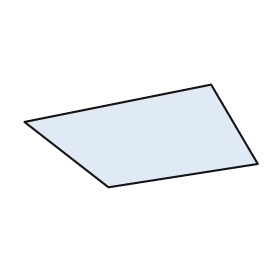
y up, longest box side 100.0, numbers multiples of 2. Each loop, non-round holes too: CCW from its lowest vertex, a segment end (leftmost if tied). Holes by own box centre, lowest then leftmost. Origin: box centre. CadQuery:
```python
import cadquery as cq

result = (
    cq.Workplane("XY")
    .moveTo(-14.0, -22.0)
    .lineTo(50.0, -12.0)
    .lineTo(30.0, 22.0)
    .lineTo(-50.0, 6.0)
    .close()
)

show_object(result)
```